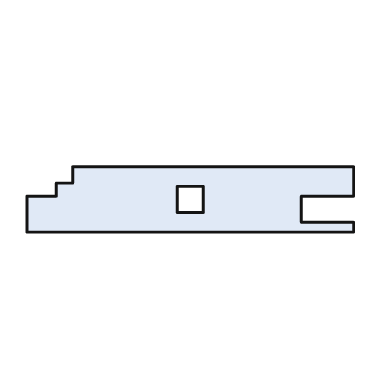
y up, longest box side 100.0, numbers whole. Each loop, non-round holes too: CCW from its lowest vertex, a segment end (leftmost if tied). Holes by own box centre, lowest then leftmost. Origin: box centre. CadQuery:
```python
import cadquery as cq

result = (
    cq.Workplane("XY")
    .moveTo(-50.0, -10.0)
    .lineTo(50.0, -10.0)
    .lineTo(50.0, -7.0)
    .lineTo(34.0, -7.0)
    .lineTo(34.0, 1.0)
    .lineTo(50.0, 1.0)
    .lineTo(50.0, 10.0)
    .lineTo(-36.0, 10.0)
    .lineTo(-36.0, 5.0)
    .lineTo(-41.0, 5.0)
    .lineTo(-41.0, 1.0)
    .lineTo(-50.0, 1.0)
    .close()
    .moveTo(-4.0, -4.0)
    .lineTo(4.0, -4.0)
    .lineTo(4.0, 4.0)
    .lineTo(-4.0, 4.0)
    .close()
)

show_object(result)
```